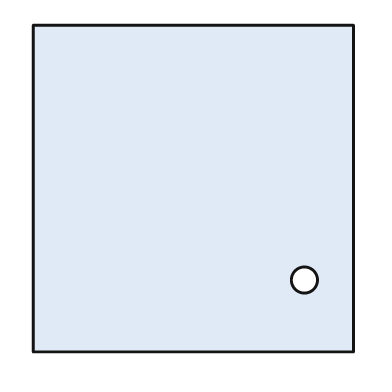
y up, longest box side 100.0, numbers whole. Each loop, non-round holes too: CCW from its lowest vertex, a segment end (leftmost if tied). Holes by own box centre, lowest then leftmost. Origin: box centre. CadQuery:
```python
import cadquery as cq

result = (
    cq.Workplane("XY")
    .moveTo(-49.0, -50.0)
    .lineTo(49.0, -50.0)
    .lineTo(49.0, 50.0)
    .lineTo(-49.0, 50.0)
    .close()
    .moveTo(34.0, -28.0)
    .circle(4.0)
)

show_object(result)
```